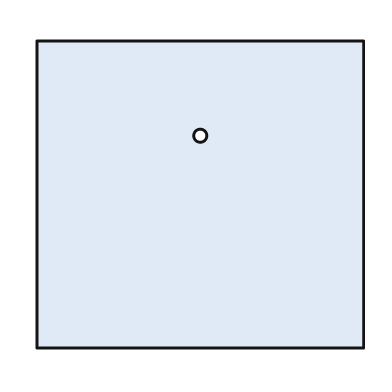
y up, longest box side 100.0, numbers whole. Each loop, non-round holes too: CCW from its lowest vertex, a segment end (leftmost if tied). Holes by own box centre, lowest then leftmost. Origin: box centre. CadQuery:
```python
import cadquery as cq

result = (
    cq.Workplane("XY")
    .moveTo(-50.0, -47.0)
    .lineTo(50.0, -47.0)
    .lineTo(50.0, 47.0)
    .lineTo(-50.0, 47.0)
    .close()
    .moveTo(0.0, 18.0)
    .circle(2.0)
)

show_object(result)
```